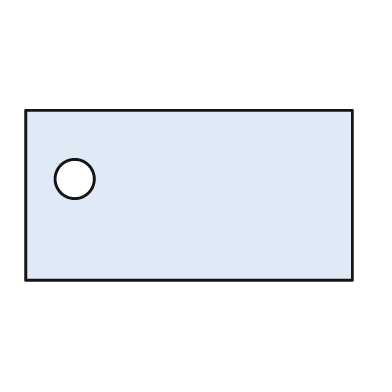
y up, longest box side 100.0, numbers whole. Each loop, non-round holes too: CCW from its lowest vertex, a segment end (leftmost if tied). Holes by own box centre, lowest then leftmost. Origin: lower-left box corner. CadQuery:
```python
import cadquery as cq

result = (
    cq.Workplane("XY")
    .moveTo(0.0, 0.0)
    .lineTo(100.0, 0.0)
    .lineTo(100.0, 52.0)
    .lineTo(0.0, 52.0)
    .close()
    .moveTo(15.0, 31.0)
    .circle(6.0)
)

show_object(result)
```